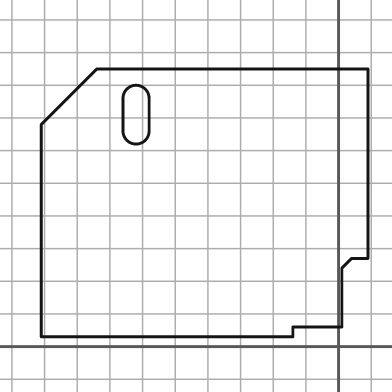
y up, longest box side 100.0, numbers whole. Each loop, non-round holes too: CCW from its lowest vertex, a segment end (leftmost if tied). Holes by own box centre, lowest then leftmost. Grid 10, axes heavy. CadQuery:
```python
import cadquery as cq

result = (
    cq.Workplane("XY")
    .moveTo(-91.0, 3.0)
    .lineTo(-14.0, 3.0)
    .lineTo(-14.0, 6.0)
    .lineTo(1.0, 6.0)
    .lineTo(1.0, 24.0)
    .lineTo(4.0, 27.0)
    .lineTo(9.0, 27.0)
    .lineTo(9.0, 85.0)
    .lineTo(-74.0, 85.0)
    .lineTo(-91.0, 68.0)
    .close()
    .moveTo(-66.0, 66.0)
    .threePointArc((-62.0, 62.0), (-58.0, 66.0))
    .lineTo(-58.0, 76.0)
    .threePointArc((-62.0, 80.0), (-66.0, 76.0))
    .close()
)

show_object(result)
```